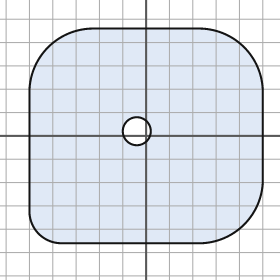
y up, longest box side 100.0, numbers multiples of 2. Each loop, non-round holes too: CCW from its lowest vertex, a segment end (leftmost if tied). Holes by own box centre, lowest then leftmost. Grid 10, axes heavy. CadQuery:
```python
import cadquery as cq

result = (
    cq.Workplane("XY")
    .moveTo(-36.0, -46.0)
    .lineTo(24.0, -46.0)
    .threePointArc((42.0, -38.0), (50.0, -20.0))
    .lineTo(50.0, 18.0)
    .threePointArc((42.0, 38.0), (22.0, 46.0))
    .lineTo(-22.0, 46.0)
    .threePointArc((-42.0, 38.0), (-50.0, 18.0))
    .lineTo(-50.0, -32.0)
    .threePointArc((-46.0, -42.0), (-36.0, -46.0))
    .close()
    .moveTo(-4.0, 2.0)
    .circle(6.0)
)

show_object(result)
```